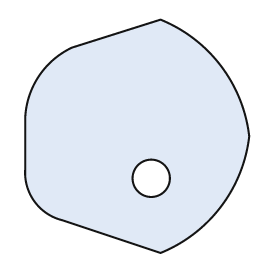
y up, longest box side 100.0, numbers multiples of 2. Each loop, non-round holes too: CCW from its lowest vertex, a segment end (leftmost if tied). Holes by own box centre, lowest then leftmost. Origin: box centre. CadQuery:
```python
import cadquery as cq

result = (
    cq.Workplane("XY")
    .moveTo(10.0, -50.0)
    .threePointArc((36.0, -30.0), (48.0, 0.0))
    .threePointArc((36.0, 30.0), (10.0, 50.0))
    .lineTo(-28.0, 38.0)
    .threePointArc((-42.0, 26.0), (-48.0, 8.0))
    .lineTo(-48.0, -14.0)
    .threePointArc((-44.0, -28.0), (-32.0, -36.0))
    .close()
    .moveTo(6.0, -18.0)
    .circle(8.0)
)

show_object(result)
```